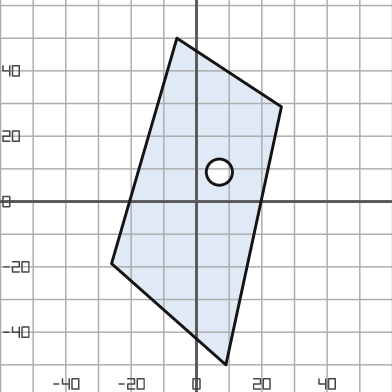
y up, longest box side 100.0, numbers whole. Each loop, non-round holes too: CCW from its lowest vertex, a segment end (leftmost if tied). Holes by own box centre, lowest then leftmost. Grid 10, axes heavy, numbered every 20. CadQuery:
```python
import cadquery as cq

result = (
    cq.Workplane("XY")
    .moveTo(9.0, -50.0)
    .lineTo(26.0, 29.0)
    .lineTo(-6.0, 50.0)
    .lineTo(-26.0, -19.0)
    .close()
    .moveTo(7.0, 9.0)
    .circle(4.0)
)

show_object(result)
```